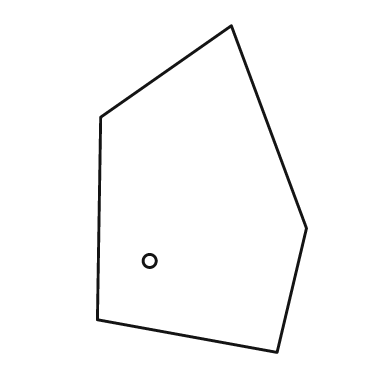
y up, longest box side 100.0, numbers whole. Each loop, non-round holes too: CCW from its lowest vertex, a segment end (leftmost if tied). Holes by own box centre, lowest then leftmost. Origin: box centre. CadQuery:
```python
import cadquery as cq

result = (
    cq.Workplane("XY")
    .moveTo(23.0, -50.0)
    .lineTo(32.0, -12.0)
    .lineTo(9.0, 50.0)
    .lineTo(-31.0, 22.0)
    .lineTo(-32.0, -40.0)
    .close()
    .moveTo(-16.0, -22.0)
    .circle(2.0)
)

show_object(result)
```